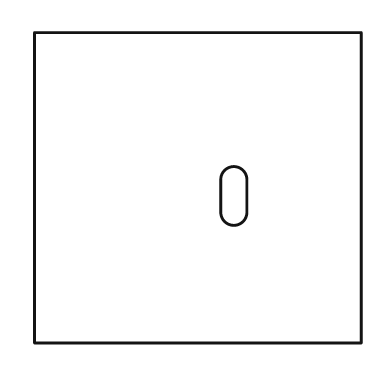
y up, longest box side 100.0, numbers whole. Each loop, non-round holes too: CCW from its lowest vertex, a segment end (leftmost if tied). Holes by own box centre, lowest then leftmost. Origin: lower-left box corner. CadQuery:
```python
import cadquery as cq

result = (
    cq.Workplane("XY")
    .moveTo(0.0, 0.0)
    .lineTo(100.0, 0.0)
    .lineTo(100.0, 95.0)
    .lineTo(0.0, 95.0)
    .close()
    .moveTo(57.0, 40.0)
    .threePointArc((61.0, 36.0), (65.0, 40.0))
    .lineTo(65.0, 50.0)
    .threePointArc((61.0, 54.0), (57.0, 50.0))
    .close()
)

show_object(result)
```